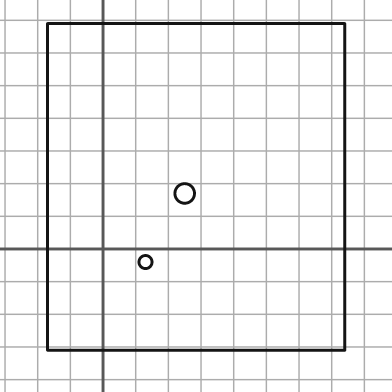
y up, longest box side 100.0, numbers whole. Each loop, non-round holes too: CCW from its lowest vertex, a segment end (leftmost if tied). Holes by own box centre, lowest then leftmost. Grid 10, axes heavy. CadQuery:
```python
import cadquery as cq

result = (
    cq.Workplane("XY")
    .moveTo(-17.0, -31.0)
    .lineTo(74.0, -31.0)
    .lineTo(74.0, 69.0)
    .lineTo(-17.0, 69.0)
    .close()
    .moveTo(13.0, -4.0)
    .circle(2.0)
    .moveTo(25.0, 17.0)
    .circle(3.0)
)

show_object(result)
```